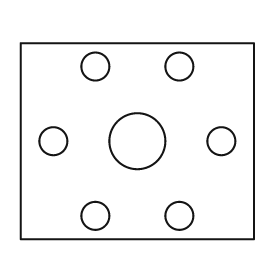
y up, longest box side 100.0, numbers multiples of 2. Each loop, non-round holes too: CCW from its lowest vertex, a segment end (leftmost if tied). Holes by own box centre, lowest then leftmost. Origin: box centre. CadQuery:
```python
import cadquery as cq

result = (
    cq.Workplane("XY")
    .moveTo(-50.0, -42.0)
    .lineTo(50.0, -42.0)
    .lineTo(50.0, 42.0)
    .lineTo(-50.0, 42.0)
    .close()
    .moveTo(-18.0, -32.0)
    .circle(6.0)
    .moveTo(18.0, -32.0)
    .circle(6.0)
    .moveTo(-36.0, 0.0)
    .circle(6.0)
    .moveTo(0.0, 0.0)
    .circle(12.0)
    .moveTo(36.0, 0.0)
    .circle(6.0)
    .moveTo(-18.0, 32.0)
    .circle(6.0)
    .moveTo(18.0, 32.0)
    .circle(6.0)
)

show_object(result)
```